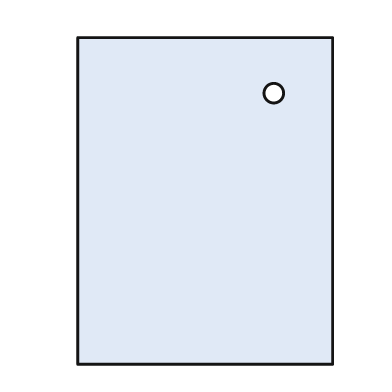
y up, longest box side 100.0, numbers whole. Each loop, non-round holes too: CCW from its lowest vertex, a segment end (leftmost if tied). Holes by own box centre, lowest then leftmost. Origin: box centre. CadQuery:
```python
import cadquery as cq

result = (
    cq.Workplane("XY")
    .moveTo(-39.0, -50.0)
    .lineTo(39.0, -50.0)
    .lineTo(39.0, 50.0)
    .lineTo(-39.0, 50.0)
    .close()
    .moveTo(21.0, 33.0)
    .circle(3.0)
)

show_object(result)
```